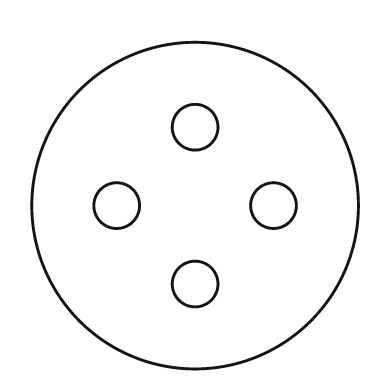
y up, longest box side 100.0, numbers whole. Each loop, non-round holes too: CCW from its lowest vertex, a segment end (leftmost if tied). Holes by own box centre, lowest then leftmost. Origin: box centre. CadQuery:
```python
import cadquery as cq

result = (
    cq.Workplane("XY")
    .moveTo(0.0, 0.0)
    .circle(50.0)
    .moveTo(0.0, -24.0)
    .circle(7.0)
    .moveTo(-24.0, 0.0)
    .circle(7.0)
    .moveTo(24.0, 0.0)
    .circle(7.0)
    .moveTo(0.0, 24.0)
    .circle(7.0)
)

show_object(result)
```